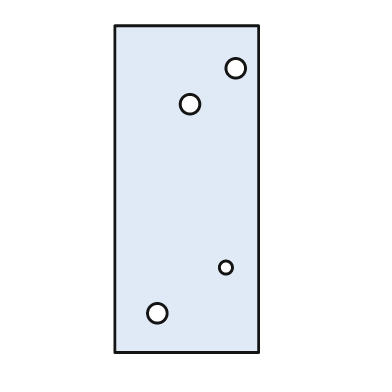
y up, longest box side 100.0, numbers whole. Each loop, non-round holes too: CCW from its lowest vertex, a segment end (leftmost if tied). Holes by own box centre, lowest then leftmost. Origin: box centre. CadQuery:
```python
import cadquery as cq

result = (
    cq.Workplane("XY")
    .moveTo(-22.0, -50.0)
    .lineTo(22.0, -50.0)
    .lineTo(22.0, 50.0)
    .lineTo(-22.0, 50.0)
    .close()
    .moveTo(-9.0, -38.0)
    .circle(3.0)
    .moveTo(12.0, -24.0)
    .circle(2.0)
    .moveTo(1.0, 26.0)
    .circle(3.0)
    .moveTo(15.0, 37.0)
    .circle(3.0)
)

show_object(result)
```